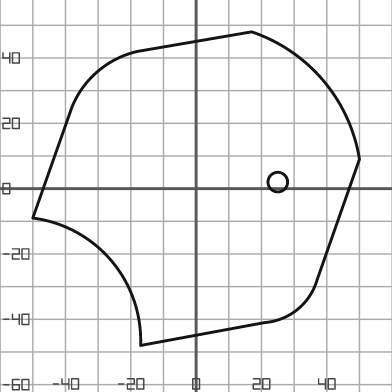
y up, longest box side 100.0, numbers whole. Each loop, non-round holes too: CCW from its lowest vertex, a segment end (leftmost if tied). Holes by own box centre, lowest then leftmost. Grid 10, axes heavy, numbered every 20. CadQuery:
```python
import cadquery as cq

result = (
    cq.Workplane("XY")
    .moveTo(-17.0, -48.0)
    .lineTo(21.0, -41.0)
    .threePointArc((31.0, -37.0), (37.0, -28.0))
    .lineTo(50.0, 9.0)
    .threePointArc((39.0, 33.0), (17.0, 48.0))
    .lineTo(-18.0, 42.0)
    .threePointArc((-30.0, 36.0), (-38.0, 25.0))
    .lineTo(-50.0, -9.0)
    .threePointArc((-26.0, -22.0), (-17.0, -48.0))
    .close()
    .moveTo(25.0, 2.0)
    .circle(3.0)
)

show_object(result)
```